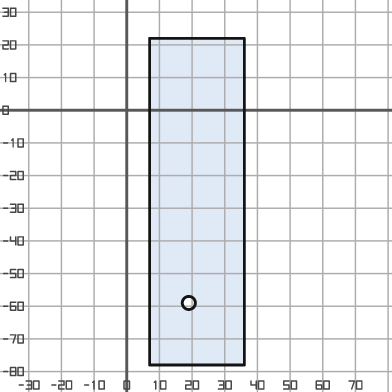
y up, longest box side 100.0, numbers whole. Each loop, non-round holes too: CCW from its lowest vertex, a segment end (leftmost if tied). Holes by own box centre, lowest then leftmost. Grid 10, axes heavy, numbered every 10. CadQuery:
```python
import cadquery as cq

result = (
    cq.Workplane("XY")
    .moveTo(7.0, -78.0)
    .lineTo(36.0, -78.0)
    .lineTo(36.0, 22.0)
    .lineTo(7.0, 22.0)
    .close()
    .moveTo(19.0, -59.0)
    .circle(2.0)
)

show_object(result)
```